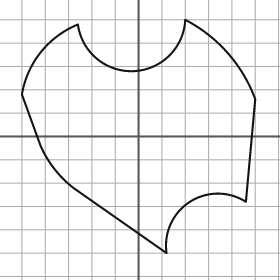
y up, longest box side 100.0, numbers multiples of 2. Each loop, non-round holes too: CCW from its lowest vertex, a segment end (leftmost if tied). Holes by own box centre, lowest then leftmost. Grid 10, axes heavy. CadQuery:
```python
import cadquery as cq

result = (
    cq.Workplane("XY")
    .moveTo(12.0, -50.0)
    .threePointArc((22.0, -28.0), (46.0, -28.0))
    .lineTo(50.0, 16.0)
    .threePointArc((38.0, 36.0), (20.0, 50.0))
    .threePointArc((-2.0, 28.0), (-26.0, 48.0))
    .threePointArc((-42.0, 36.0), (-50.0, 18.0))
    .lineTo(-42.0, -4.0)
    .threePointArc((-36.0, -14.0), (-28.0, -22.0))
    .close()
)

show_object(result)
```